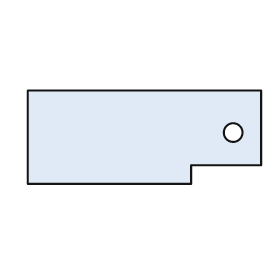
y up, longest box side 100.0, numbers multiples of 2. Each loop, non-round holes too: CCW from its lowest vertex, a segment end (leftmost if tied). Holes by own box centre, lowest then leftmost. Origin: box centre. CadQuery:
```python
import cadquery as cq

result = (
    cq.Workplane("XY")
    .moveTo(-50.0, -20.0)
    .lineTo(20.0, -20.0)
    .lineTo(20.0, -12.0)
    .lineTo(50.0, -12.0)
    .lineTo(50.0, 20.0)
    .lineTo(-50.0, 20.0)
    .close()
    .moveTo(38.0, 2.0)
    .circle(4.0)
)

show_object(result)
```